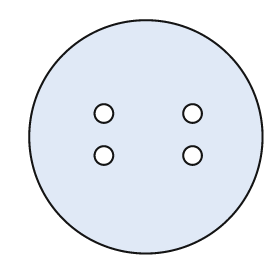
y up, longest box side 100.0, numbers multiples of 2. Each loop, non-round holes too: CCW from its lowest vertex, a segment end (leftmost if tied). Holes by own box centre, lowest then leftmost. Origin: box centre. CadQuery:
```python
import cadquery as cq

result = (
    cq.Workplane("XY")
    .moveTo(0.0, 0.0)
    .circle(50.0)
    .moveTo(-18.0, -8.0)
    .circle(4.0)
    .moveTo(20.0, -8.0)
    .circle(4.0)
    .moveTo(-18.0, 10.0)
    .circle(4.0)
    .moveTo(20.0, 10.0)
    .circle(4.0)
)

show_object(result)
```